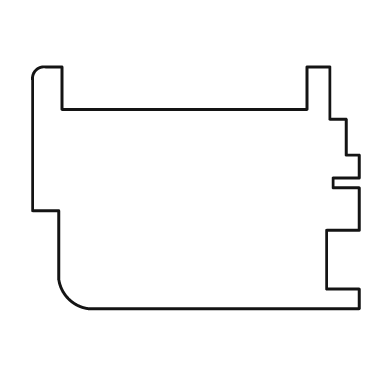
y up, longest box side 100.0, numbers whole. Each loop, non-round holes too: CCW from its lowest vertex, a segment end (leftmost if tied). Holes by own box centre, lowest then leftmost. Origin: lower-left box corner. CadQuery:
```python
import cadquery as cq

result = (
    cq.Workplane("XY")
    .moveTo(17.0, 0.0)
    .lineTo(100.0, 0.0)
    .lineTo(100.0, 6.0)
    .lineTo(90.0, 6.0)
    .lineTo(90.0, 24.0)
    .lineTo(100.0, 24.0)
    .lineTo(100.0, 37.0)
    .lineTo(92.0, 37.0)
    .lineTo(92.0, 40.0)
    .lineTo(100.0, 40.0)
    .lineTo(100.0, 47.0)
    .lineTo(96.0, 47.0)
    .lineTo(96.0, 58.0)
    .lineTo(91.0, 58.0)
    .lineTo(91.0, 74.0)
    .lineTo(84.0, 74.0)
    .lineTo(84.0, 61.0)
    .lineTo(9.0, 61.0)
    .lineTo(9.0, 74.0)
    .lineTo(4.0, 74.0)
    .threePointArc((1.0, 73.0), (0.0, 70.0))
    .lineTo(0.0, 30.0)
    .lineTo(8.0, 30.0)
    .lineTo(8.0, 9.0)
    .threePointArc((11.0, 3.0), (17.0, 0.0))
    .close()
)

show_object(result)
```